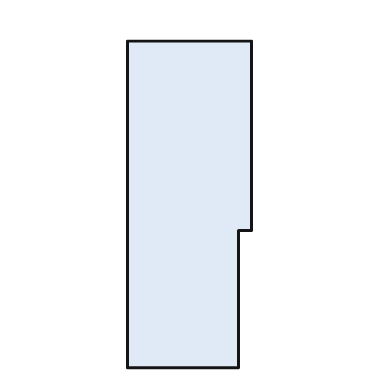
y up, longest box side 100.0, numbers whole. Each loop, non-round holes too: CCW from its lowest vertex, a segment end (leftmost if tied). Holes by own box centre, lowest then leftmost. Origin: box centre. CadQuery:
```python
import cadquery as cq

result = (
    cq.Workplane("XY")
    .moveTo(-19.0, -50.0)
    .lineTo(15.0, -50.0)
    .lineTo(15.0, -8.0)
    .lineTo(19.0, -8.0)
    .lineTo(19.0, 50.0)
    .lineTo(-19.0, 50.0)
    .close()
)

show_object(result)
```